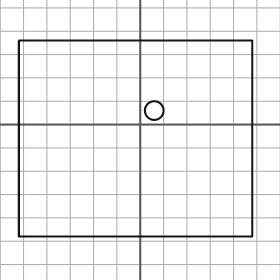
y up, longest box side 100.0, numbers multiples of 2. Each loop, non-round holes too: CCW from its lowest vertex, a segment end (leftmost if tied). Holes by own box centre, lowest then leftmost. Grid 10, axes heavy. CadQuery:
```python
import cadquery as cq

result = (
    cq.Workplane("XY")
    .moveTo(-52.0, -48.0)
    .lineTo(48.0, -48.0)
    .lineTo(48.0, 36.0)
    .lineTo(-52.0, 36.0)
    .close()
    .moveTo(6.0, 6.0)
    .circle(4.0)
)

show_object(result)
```